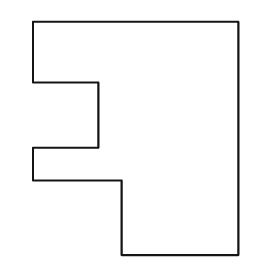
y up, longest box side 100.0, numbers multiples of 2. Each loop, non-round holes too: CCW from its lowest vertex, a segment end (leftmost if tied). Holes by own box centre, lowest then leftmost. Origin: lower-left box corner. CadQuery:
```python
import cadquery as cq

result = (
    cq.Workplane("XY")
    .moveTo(38.0, 0.0)
    .lineTo(88.0, 0.0)
    .lineTo(88.0, 100.0)
    .lineTo(0.0, 100.0)
    .lineTo(0.0, 74.0)
    .lineTo(28.0, 74.0)
    .lineTo(28.0, 46.0)
    .lineTo(0.0, 46.0)
    .lineTo(0.0, 32.0)
    .lineTo(38.0, 32.0)
    .close()
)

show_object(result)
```